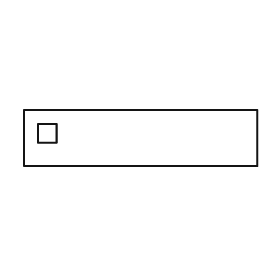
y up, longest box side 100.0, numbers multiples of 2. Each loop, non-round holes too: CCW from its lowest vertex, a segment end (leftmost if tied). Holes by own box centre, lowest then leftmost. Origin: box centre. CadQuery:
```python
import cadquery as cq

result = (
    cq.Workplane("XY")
    .moveTo(-50.0, -12.0)
    .lineTo(50.0, -12.0)
    .lineTo(50.0, 12.0)
    .lineTo(-50.0, 12.0)
    .close()
    .moveTo(-44.0, -2.0)
    .lineTo(-36.0, -2.0)
    .lineTo(-36.0, 6.0)
    .lineTo(-44.0, 6.0)
    .close()
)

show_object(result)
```